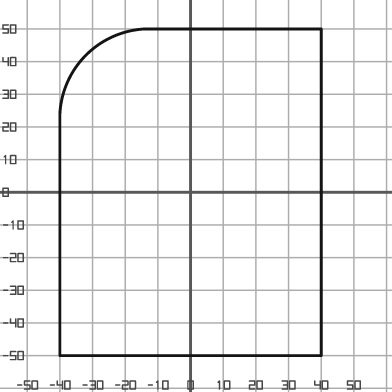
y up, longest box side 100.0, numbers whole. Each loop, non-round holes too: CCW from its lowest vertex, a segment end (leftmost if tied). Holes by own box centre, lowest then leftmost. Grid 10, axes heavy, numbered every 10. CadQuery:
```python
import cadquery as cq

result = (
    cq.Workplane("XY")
    .moveTo(-40.0, -50.0)
    .lineTo(40.0, -50.0)
    .lineTo(40.0, 50.0)
    .lineTo(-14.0, 50.0)
    .threePointArc((-32.0, 42.0), (-40.0, 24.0))
    .close()
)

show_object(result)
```